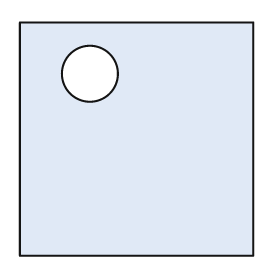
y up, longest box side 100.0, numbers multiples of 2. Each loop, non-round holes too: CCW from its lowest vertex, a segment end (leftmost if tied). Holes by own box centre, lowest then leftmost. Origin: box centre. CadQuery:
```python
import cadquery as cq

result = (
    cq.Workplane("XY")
    .moveTo(-50.0, -50.0)
    .lineTo(50.0, -50.0)
    .lineTo(50.0, 50.0)
    .lineTo(-50.0, 50.0)
    .close()
    .moveTo(-20.0, 28.0)
    .circle(12.0)
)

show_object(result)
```